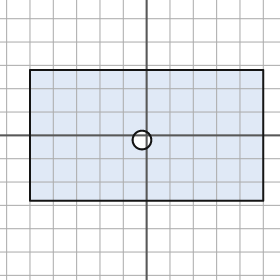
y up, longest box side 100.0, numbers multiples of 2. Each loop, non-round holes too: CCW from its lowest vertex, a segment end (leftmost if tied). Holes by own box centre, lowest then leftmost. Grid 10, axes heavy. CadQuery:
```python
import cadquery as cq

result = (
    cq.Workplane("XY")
    .moveTo(-50.0, -28.0)
    .lineTo(50.0, -28.0)
    .lineTo(50.0, 28.0)
    .lineTo(-50.0, 28.0)
    .close()
    .moveTo(-2.0, -2.0)
    .circle(4.0)
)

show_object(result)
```